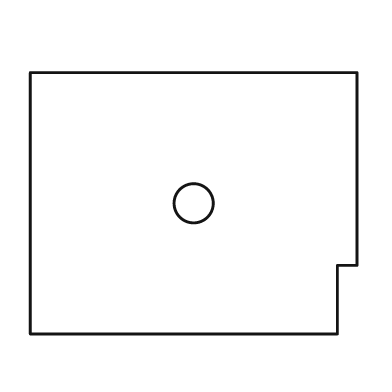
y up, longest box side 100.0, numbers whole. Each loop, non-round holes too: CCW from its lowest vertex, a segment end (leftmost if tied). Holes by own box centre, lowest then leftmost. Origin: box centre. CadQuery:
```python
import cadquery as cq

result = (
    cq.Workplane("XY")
    .moveTo(-50.0, -40.0)
    .lineTo(44.0, -40.0)
    .lineTo(44.0, -19.0)
    .lineTo(50.0, -19.0)
    .lineTo(50.0, 40.0)
    .lineTo(-50.0, 40.0)
    .close()
    .moveTo(0.0, 0.0)
    .circle(6.0)
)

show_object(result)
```